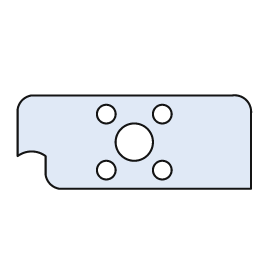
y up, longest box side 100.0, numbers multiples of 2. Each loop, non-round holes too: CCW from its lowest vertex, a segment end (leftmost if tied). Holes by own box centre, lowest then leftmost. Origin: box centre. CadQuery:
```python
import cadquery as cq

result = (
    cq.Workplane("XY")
    .moveTo(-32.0, -20.0)
    .lineTo(50.0, -20.0)
    .lineTo(50.0, 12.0)
    .threePointArc((48.0, 18.0), (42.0, 20.0))
    .lineTo(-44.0, 20.0)
    .threePointArc((-48.0, 18.0), (-50.0, 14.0))
    .lineTo(-50.0, -6.0)
    .threePointArc((-44.0, -4.0), (-38.0, -6.0))
    .lineTo(-38.0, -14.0)
    .threePointArc((-36.0, -18.0), (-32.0, -20.0))
    .close()
    .moveTo(-12.0, -12.0)
    .circle(4.0)
    .moveTo(12.0, -12.0)
    .circle(4.0)
    .moveTo(0.0, 0.0)
    .circle(8.0)
    .moveTo(-12.0, 12.0)
    .circle(4.0)
    .moveTo(12.0, 12.0)
    .circle(4.0)
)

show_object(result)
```